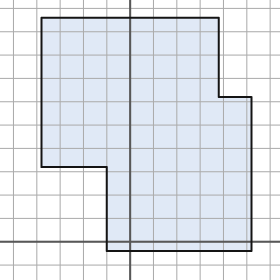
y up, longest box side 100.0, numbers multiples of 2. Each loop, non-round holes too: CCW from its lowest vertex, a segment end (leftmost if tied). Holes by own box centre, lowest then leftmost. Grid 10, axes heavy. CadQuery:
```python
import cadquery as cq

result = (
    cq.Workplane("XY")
    .moveTo(-10.0, -4.0)
    .lineTo(52.0, -4.0)
    .lineTo(52.0, 62.0)
    .lineTo(38.0, 62.0)
    .lineTo(38.0, 96.0)
    .lineTo(-38.0, 96.0)
    .lineTo(-38.0, 32.0)
    .lineTo(-10.0, 32.0)
    .close()
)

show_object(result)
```